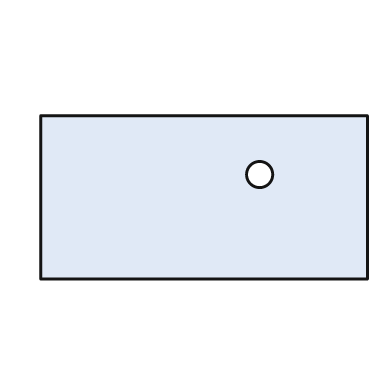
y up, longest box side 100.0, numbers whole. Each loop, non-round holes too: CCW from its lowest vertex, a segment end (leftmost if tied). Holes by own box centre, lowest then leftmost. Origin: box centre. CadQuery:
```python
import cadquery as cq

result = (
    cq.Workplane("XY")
    .moveTo(-50.0, -25.0)
    .lineTo(50.0, -25.0)
    .lineTo(50.0, 25.0)
    .lineTo(-50.0, 25.0)
    .close()
    .moveTo(17.0, 7.0)
    .circle(4.0)
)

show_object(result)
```